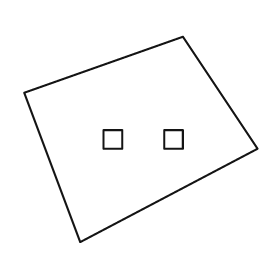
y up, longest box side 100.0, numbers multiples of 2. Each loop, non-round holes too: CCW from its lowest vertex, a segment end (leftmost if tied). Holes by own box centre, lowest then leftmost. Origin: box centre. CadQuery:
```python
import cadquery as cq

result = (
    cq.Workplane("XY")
    .moveTo(-26.0, -44.0)
    .lineTo(50.0, -4.0)
    .lineTo(18.0, 44.0)
    .lineTo(-50.0, 20.0)
    .close()
    .moveTo(-16.0, -4.0)
    .lineTo(-8.0, -4.0)
    .lineTo(-8.0, 4.0)
    .lineTo(-16.0, 4.0)
    .close()
    .moveTo(10.0, -4.0)
    .lineTo(18.0, -4.0)
    .lineTo(18.0, 4.0)
    .lineTo(10.0, 4.0)
    .close()
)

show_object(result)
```